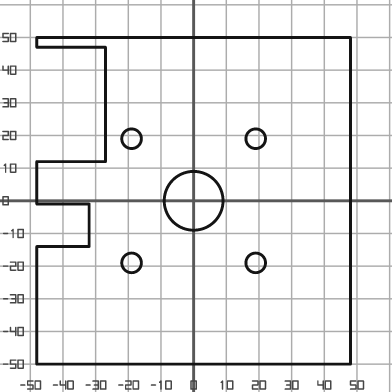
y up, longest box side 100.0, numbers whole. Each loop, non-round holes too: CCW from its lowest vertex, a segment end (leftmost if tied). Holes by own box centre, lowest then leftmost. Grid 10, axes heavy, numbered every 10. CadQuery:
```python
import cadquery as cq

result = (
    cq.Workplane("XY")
    .moveTo(-48.0, -50.0)
    .lineTo(48.0, -50.0)
    .lineTo(48.0, 50.0)
    .lineTo(-48.0, 50.0)
    .lineTo(-48.0, 47.0)
    .lineTo(-27.0, 47.0)
    .lineTo(-27.0, 12.0)
    .lineTo(-48.0, 12.0)
    .lineTo(-48.0, -1.0)
    .lineTo(-32.0, -1.0)
    .lineTo(-32.0, -14.0)
    .lineTo(-48.0, -14.0)
    .close()
    .moveTo(-19.0, -19.0)
    .circle(3.0)
    .moveTo(19.0, -19.0)
    .circle(3.0)
    .moveTo(0.0, 0.0)
    .circle(9.0)
    .moveTo(-19.0, 19.0)
    .circle(3.0)
    .moveTo(19.0, 19.0)
    .circle(3.0)
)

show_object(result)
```